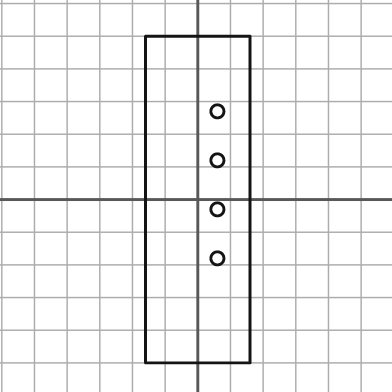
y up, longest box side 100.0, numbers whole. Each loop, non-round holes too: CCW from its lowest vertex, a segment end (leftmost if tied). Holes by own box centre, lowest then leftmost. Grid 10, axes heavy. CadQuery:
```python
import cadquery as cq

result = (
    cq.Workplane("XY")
    .moveTo(-16.0, -50.0)
    .lineTo(16.0, -50.0)
    .lineTo(16.0, 50.0)
    .lineTo(-16.0, 50.0)
    .close()
    .moveTo(6.0, -18.0)
    .circle(2.0)
    .moveTo(6.0, -3.0)
    .circle(2.0)
    .moveTo(6.0, 12.0)
    .circle(2.0)
    .moveTo(6.0, 27.0)
    .circle(2.0)
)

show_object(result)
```